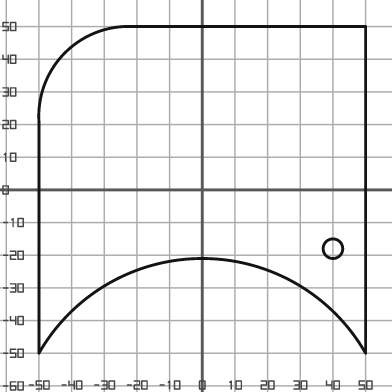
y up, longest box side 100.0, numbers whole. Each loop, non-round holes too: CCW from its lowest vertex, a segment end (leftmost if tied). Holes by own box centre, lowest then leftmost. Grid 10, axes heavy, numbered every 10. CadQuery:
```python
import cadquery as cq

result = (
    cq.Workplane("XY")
    .moveTo(-50.0, -50.0)
    .threePointArc((0.0, -21.0), (50.0, -50.0))
    .lineTo(50.0, 50.0)
    .lineTo(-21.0, 50.0)
    .threePointArc((-42.0, 42.0), (-50.0, 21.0))
    .close()
    .moveTo(40.0, -18.0)
    .circle(3.0)
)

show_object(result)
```